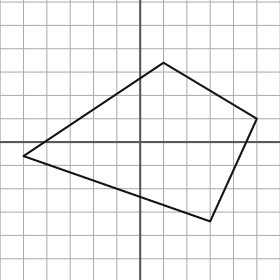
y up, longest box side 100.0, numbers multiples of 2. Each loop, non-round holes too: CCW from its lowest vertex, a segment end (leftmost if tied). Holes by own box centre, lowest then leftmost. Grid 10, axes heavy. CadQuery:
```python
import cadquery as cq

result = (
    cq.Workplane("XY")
    .moveTo(30.0, -34.0)
    .lineTo(50.0, 10.0)
    .lineTo(10.0, 34.0)
    .lineTo(-50.0, -6.0)
    .close()
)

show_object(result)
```